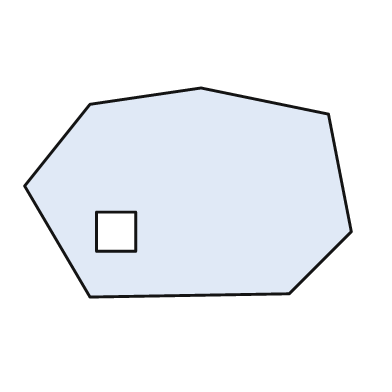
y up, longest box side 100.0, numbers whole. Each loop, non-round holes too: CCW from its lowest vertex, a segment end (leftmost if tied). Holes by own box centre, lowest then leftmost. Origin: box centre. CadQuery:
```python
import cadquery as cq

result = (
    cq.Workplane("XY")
    .moveTo(-30.0, -32.0)
    .lineTo(31.0, -31.0)
    .lineTo(50.0, -12.0)
    .lineTo(43.0, 24.0)
    .lineTo(4.0, 32.0)
    .lineTo(-30.0, 27.0)
    .lineTo(-50.0, 2.0)
    .close()
    .moveTo(-28.0, -18.0)
    .lineTo(-16.0, -18.0)
    .lineTo(-16.0, -6.0)
    .lineTo(-28.0, -6.0)
    .close()
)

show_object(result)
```